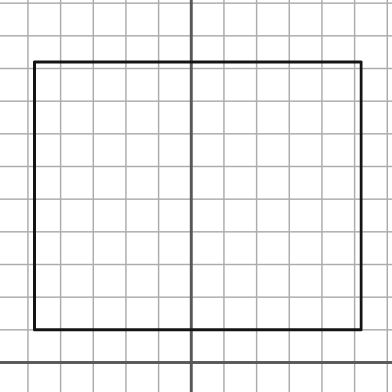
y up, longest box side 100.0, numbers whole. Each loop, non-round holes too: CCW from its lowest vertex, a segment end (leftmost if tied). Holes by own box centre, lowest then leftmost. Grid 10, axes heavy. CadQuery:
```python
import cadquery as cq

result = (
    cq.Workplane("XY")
    .moveTo(-48.0, 10.0)
    .lineTo(52.0, 10.0)
    .lineTo(52.0, 92.0)
    .lineTo(-48.0, 92.0)
    .close()
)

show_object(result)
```